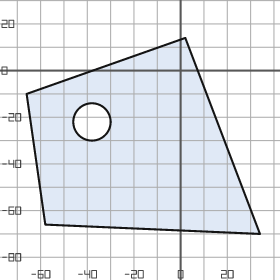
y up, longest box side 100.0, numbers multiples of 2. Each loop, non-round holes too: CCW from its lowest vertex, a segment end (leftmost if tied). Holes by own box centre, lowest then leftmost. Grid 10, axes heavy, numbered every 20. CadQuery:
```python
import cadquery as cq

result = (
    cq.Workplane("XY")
    .moveTo(34.0, -70.0)
    .lineTo(2.0, 14.0)
    .lineTo(-66.0, -10.0)
    .lineTo(-58.0, -66.0)
    .close()
    .moveTo(-38.0, -22.0)
    .circle(8.0)
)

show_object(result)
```